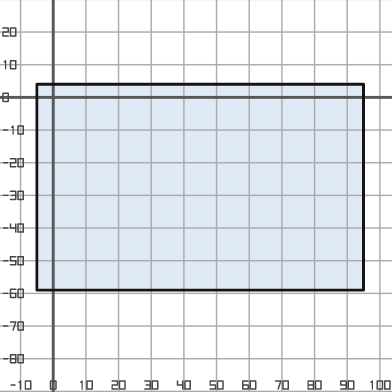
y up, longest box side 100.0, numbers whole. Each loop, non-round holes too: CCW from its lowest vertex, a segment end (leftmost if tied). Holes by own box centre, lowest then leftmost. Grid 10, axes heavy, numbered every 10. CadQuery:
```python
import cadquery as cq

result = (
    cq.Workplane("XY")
    .moveTo(-5.0, -59.0)
    .lineTo(95.0, -59.0)
    .lineTo(95.0, 4.0)
    .lineTo(-5.0, 4.0)
    .close()
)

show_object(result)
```